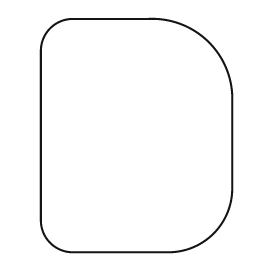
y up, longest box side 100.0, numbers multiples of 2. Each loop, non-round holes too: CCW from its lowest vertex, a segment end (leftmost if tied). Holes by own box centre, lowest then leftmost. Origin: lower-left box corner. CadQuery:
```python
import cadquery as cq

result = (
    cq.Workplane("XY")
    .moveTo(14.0, 0.0)
    .lineTo(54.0, 0.0)
    .threePointArc((74.0, 8.0), (82.0, 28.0))
    .lineTo(82.0, 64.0)
    .threePointArc((72.0, 90.0), (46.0, 100.0))
    .lineTo(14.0, 100.0)
    .threePointArc((4.0, 96.0), (0.0, 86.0))
    .lineTo(0.0, 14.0)
    .threePointArc((4.0, 4.0), (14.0, 0.0))
    .close()
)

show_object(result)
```